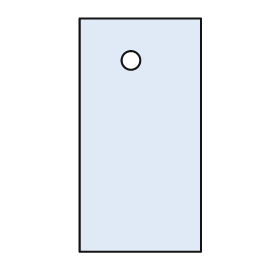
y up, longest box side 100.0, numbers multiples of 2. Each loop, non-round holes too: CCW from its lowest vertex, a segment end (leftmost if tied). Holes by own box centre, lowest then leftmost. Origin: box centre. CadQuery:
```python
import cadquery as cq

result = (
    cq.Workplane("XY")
    .moveTo(-26.0, -50.0)
    .lineTo(26.0, -50.0)
    .lineTo(26.0, 50.0)
    .lineTo(-26.0, 50.0)
    .close()
    .moveTo(-4.0, 32.0)
    .circle(4.0)
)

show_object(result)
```